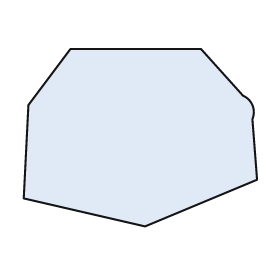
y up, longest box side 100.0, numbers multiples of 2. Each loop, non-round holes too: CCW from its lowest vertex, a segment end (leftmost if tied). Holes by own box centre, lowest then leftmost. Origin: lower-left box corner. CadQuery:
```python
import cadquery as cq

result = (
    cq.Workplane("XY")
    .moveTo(52.0, 0.0)
    .lineTo(100.0, 20.0)
    .lineTo(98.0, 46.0)
    .threePointArc((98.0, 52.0), (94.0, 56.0))
    .lineTo(76.0, 76.0)
    .lineTo(20.0, 76.0)
    .lineTo(2.0, 52.0)
    .lineTo(0.0, 12.0)
    .close()
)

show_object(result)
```